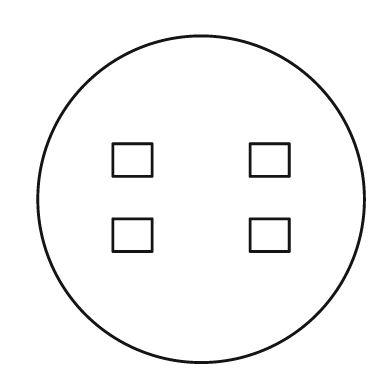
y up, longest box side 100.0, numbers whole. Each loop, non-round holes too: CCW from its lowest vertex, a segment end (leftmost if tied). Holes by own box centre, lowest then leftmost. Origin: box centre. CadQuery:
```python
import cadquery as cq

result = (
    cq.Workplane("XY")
    .moveTo(0.0, 0.0)
    .circle(50.0)
    .moveTo(-27.0, -16.0)
    .lineTo(-15.0, -16.0)
    .lineTo(-15.0, -6.0)
    .lineTo(-27.0, -6.0)
    .close()
    .moveTo(15.0, -16.0)
    .lineTo(27.0, -16.0)
    .lineTo(27.0, -6.0)
    .lineTo(15.0, -6.0)
    .close()
    .moveTo(-27.0, 7.0)
    .lineTo(-15.0, 7.0)
    .lineTo(-15.0, 17.0)
    .lineTo(-27.0, 17.0)
    .close()
    .moveTo(15.0, 7.0)
    .lineTo(27.0, 7.0)
    .lineTo(27.0, 17.0)
    .lineTo(15.0, 17.0)
    .close()
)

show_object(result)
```